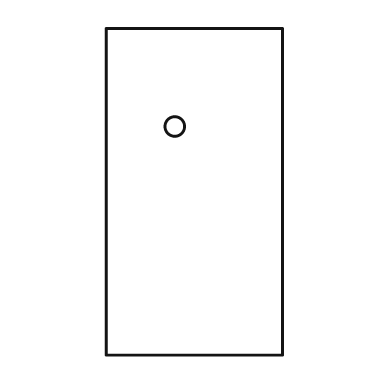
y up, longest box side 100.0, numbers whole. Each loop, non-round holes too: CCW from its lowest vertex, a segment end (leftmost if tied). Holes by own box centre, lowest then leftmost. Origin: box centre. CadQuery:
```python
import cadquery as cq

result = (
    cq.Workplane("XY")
    .moveTo(-27.0, -50.0)
    .lineTo(27.0, -50.0)
    .lineTo(27.0, 50.0)
    .lineTo(-27.0, 50.0)
    .close()
    .moveTo(-6.0, 20.0)
    .circle(3.0)
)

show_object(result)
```